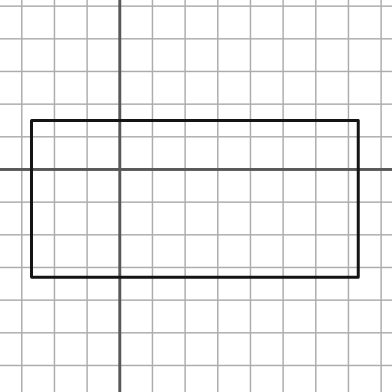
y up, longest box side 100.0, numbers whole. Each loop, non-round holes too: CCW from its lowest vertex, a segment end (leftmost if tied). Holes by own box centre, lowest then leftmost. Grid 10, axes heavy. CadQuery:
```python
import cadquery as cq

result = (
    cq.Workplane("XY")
    .moveTo(-27.0, -33.0)
    .lineTo(73.0, -33.0)
    .lineTo(73.0, 15.0)
    .lineTo(-27.0, 15.0)
    .close()
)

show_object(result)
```